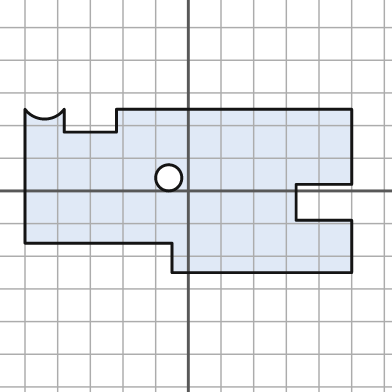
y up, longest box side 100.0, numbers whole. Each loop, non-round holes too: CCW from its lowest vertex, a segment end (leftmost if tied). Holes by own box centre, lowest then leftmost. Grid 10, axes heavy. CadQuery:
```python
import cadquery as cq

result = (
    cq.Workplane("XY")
    .moveTo(-5.0, -25.0)
    .lineTo(50.0, -25.0)
    .lineTo(50.0, -9.0)
    .lineTo(33.0, -9.0)
    .lineTo(33.0, 2.0)
    .lineTo(50.0, 2.0)
    .lineTo(50.0, 25.0)
    .lineTo(-22.0, 25.0)
    .lineTo(-22.0, 18.0)
    .lineTo(-38.0, 18.0)
    .lineTo(-38.0, 25.0)
    .threePointArc((-44.0, 22.0), (-50.0, 25.0))
    .lineTo(-50.0, -16.0)
    .lineTo(-5.0, -16.0)
    .close()
    .moveTo(-6.0, 4.0)
    .circle(4.0)
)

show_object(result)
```